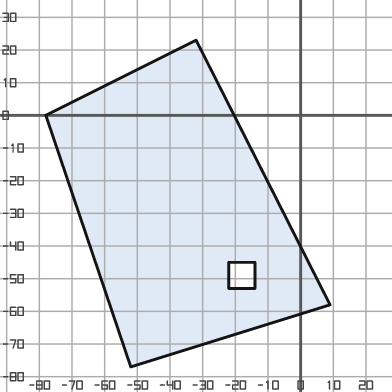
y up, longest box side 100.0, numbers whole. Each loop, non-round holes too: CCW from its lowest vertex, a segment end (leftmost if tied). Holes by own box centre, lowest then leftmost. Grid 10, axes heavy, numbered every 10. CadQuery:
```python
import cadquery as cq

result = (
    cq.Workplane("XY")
    .moveTo(-52.0, -77.0)
    .lineTo(9.0, -58.0)
    .lineTo(-32.0, 23.0)
    .lineTo(-78.0, 0.0)
    .close()
    .moveTo(-22.0, -53.0)
    .lineTo(-14.0, -53.0)
    .lineTo(-14.0, -45.0)
    .lineTo(-22.0, -45.0)
    .close()
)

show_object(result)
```